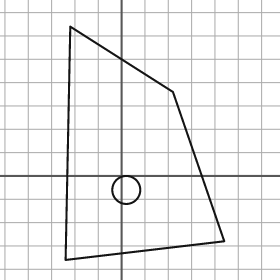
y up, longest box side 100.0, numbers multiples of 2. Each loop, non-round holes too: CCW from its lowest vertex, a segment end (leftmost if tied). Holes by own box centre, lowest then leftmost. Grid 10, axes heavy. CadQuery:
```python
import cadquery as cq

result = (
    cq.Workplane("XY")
    .moveTo(-24.0, -36.0)
    .lineTo(44.0, -28.0)
    .lineTo(22.0, 36.0)
    .lineTo(-22.0, 64.0)
    .close()
    .moveTo(2.0, -6.0)
    .circle(6.0)
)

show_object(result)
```